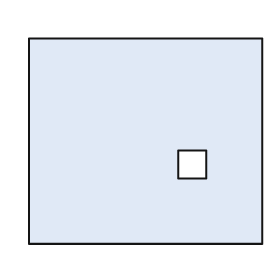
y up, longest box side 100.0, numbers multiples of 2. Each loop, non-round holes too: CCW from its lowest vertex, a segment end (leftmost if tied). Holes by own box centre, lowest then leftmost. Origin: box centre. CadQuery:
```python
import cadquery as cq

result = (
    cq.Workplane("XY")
    .moveTo(-50.0, -44.0)
    .lineTo(50.0, -44.0)
    .lineTo(50.0, 44.0)
    .lineTo(-50.0, 44.0)
    .close()
    .moveTo(14.0, -16.0)
    .lineTo(26.0, -16.0)
    .lineTo(26.0, -4.0)
    .lineTo(14.0, -4.0)
    .close()
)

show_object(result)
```